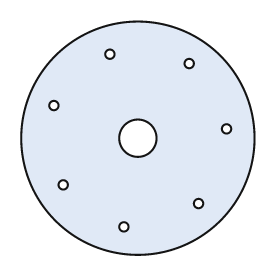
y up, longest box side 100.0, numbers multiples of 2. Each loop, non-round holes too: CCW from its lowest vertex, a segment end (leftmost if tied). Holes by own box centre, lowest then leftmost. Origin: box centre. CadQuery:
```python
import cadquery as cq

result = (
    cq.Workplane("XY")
    .moveTo(0.0, 0.0)
    .circle(50.0)
    .moveTo(-6.0, -38.0)
    .circle(2.0)
    .moveTo(26.0, -28.0)
    .circle(2.0)
    .moveTo(-32.0, -20.0)
    .circle(2.0)
    .moveTo(0.0, 0.0)
    .circle(8.0)
    .moveTo(38.0, 4.0)
    .circle(2.0)
    .moveTo(-36.0, 14.0)
    .circle(2.0)
    .moveTo(22.0, 32.0)
    .circle(2.0)
    .moveTo(-12.0, 36.0)
    .circle(2.0)
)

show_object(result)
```